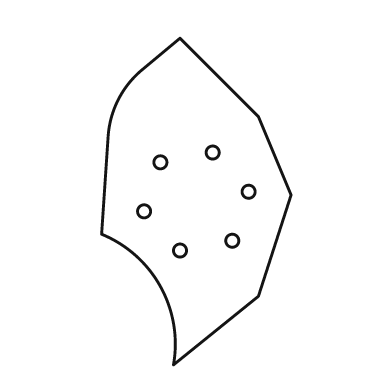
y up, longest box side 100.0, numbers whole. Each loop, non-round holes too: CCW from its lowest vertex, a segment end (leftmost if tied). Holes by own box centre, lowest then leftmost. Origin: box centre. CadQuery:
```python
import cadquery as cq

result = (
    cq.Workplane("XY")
    .moveTo(-7.0, -50.0)
    .lineTo(19.0, -29.0)
    .lineTo(29.0, 2.0)
    .lineTo(19.0, 26.0)
    .lineTo(-5.0, 50.0)
    .lineTo(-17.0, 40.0)
    .threePointArc((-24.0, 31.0), (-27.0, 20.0))
    .lineTo(-29.0, -10.0)
    .threePointArc((-11.0, -26.0), (-7.0, -50.0))
    .close()
    .moveTo(-5.0, -15.0)
    .circle(2.0)
    .moveTo(11.0, -12.0)
    .circle(2.0)
    .moveTo(-16.0, -3.0)
    .circle(2.0)
    .moveTo(16.0, 3.0)
    .circle(2.0)
    .moveTo(-11.0, 12.0)
    .circle(2.0)
    .moveTo(5.0, 15.0)
    .circle(2.0)
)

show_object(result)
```